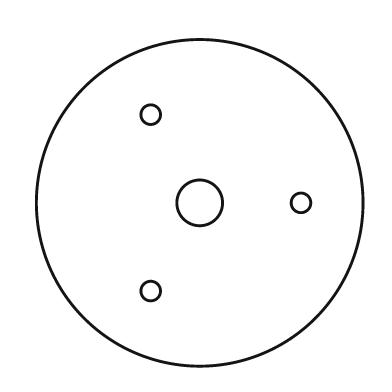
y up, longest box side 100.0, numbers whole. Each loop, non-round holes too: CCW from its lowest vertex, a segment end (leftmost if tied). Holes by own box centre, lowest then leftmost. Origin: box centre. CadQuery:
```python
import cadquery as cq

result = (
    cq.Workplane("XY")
    .moveTo(0.0, 0.0)
    .circle(50.0)
    .moveTo(-15.0, -27.0)
    .circle(3.0)
    .moveTo(0.0, 0.0)
    .circle(7.0)
    .moveTo(31.0, 0.0)
    .circle(3.0)
    .moveTo(-15.0, 27.0)
    .circle(3.0)
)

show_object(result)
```